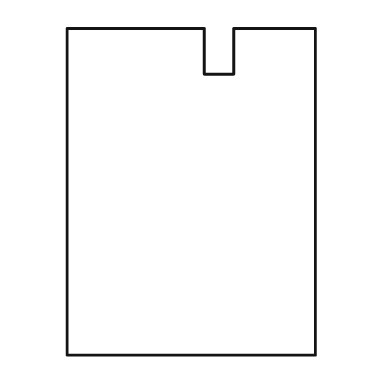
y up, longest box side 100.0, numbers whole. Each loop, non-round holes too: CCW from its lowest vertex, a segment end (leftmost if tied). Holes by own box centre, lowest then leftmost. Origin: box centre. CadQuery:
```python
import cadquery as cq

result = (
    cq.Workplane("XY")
    .moveTo(-38.0, -50.0)
    .lineTo(38.0, -50.0)
    .lineTo(38.0, 50.0)
    .lineTo(13.0, 50.0)
    .lineTo(13.0, 36.0)
    .lineTo(4.0, 36.0)
    .lineTo(4.0, 50.0)
    .lineTo(-38.0, 50.0)
    .close()
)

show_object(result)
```